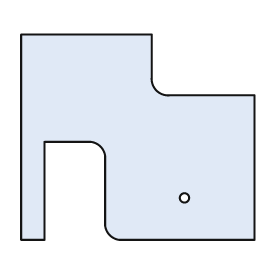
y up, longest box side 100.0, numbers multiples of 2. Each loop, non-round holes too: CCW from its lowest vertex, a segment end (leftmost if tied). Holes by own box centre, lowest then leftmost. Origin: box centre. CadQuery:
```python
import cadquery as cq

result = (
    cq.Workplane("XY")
    .moveTo(-50.0, -44.0)
    .lineTo(-40.0, -44.0)
    .lineTo(-40.0, -2.0)
    .lineTo(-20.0, -2.0)
    .threePointArc((-16.0, -4.0), (-14.0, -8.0))
    .lineTo(-14.0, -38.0)
    .threePointArc((-12.0, -42.0), (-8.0, -44.0))
    .lineTo(50.0, -44.0)
    .lineTo(50.0, 18.0)
    .lineTo(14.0, 18.0)
    .threePointArc((8.0, 20.0), (6.0, 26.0))
    .lineTo(6.0, 44.0)
    .lineTo(-50.0, 44.0)
    .close()
    .moveTo(20.0, -26.0)
    .circle(2.0)
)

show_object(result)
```